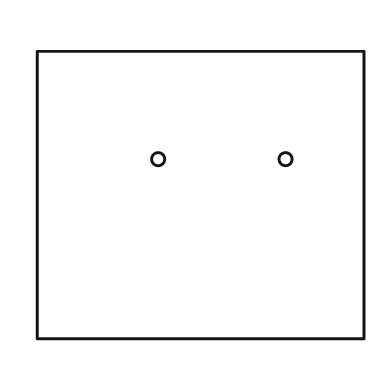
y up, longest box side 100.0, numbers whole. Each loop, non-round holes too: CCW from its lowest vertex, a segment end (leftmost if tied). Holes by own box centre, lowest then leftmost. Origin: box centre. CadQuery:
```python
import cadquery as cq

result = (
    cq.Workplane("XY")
    .moveTo(-50.0, -44.0)
    .lineTo(50.0, -44.0)
    .lineTo(50.0, 44.0)
    .lineTo(-50.0, 44.0)
    .close()
    .moveTo(-13.0, 11.0)
    .circle(2.0)
    .moveTo(26.0, 11.0)
    .circle(2.0)
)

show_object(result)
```